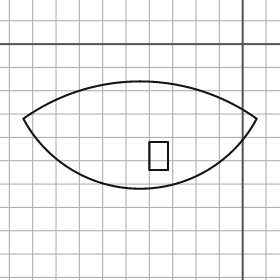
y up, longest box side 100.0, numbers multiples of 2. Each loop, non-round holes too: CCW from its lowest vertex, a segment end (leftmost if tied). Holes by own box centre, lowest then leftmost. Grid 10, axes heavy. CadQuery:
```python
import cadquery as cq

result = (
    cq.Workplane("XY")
    .moveTo(-94.0, -32.0)
    .threePointArc((-44.0, -62.0), (6.0, -32.0))
    .threePointArc((-44.0, -16.0), (-94.0, -32.0))
    .close()
    .moveTo(-40.0, -54.0)
    .lineTo(-32.0, -54.0)
    .lineTo(-32.0, -42.0)
    .lineTo(-40.0, -42.0)
    .close()
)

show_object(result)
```